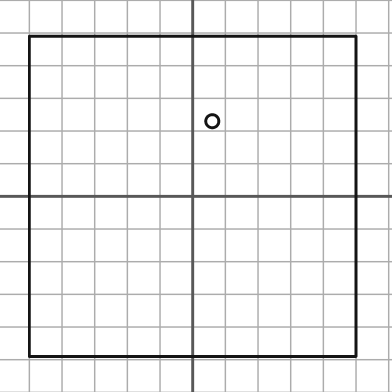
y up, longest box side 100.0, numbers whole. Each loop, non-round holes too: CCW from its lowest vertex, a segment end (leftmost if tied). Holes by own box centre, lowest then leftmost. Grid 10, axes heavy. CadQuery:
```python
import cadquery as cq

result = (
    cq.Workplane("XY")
    .moveTo(-50.0, -49.0)
    .lineTo(50.0, -49.0)
    .lineTo(50.0, 49.0)
    .lineTo(-50.0, 49.0)
    .close()
    .moveTo(6.0, 23.0)
    .circle(2.0)
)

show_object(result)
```